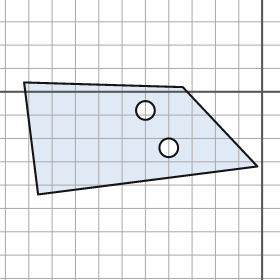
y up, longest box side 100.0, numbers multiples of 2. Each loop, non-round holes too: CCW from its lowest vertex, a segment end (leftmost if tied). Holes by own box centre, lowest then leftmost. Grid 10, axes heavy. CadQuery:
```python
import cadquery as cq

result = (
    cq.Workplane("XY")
    .moveTo(-96.0, -44.0)
    .lineTo(-2.0, -32.0)
    .lineTo(-34.0, 2.0)
    .lineTo(-102.0, 4.0)
    .close()
    .moveTo(-40.0, -24.0)
    .circle(4.0)
    .moveTo(-50.0, -8.0)
    .circle(4.0)
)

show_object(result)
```